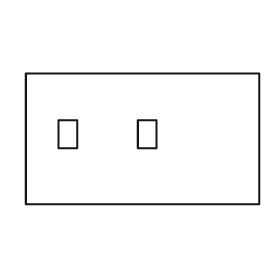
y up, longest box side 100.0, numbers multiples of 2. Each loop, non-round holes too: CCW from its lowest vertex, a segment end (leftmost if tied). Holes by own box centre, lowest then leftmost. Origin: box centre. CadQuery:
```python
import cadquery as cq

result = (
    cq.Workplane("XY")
    .moveTo(-50.0, -28.0)
    .lineTo(50.0, -28.0)
    .lineTo(50.0, 28.0)
    .lineTo(-50.0, 28.0)
    .close()
    .moveTo(-36.0, -4.0)
    .lineTo(-28.0, -4.0)
    .lineTo(-28.0, 8.0)
    .lineTo(-36.0, 8.0)
    .close()
    .moveTo(-2.0, -4.0)
    .lineTo(6.0, -4.0)
    .lineTo(6.0, 8.0)
    .lineTo(-2.0, 8.0)
    .close()
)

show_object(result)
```